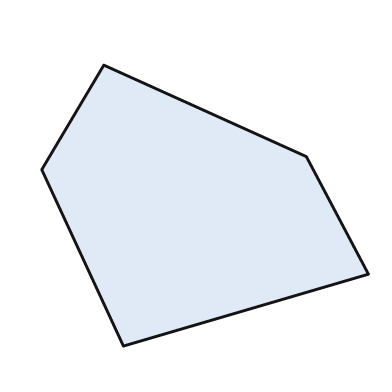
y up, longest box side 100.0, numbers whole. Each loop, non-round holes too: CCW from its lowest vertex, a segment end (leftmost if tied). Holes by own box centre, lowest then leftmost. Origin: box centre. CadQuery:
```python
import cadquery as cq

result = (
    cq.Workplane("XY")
    .moveTo(-25.0, -43.0)
    .lineTo(50.0, -21.0)
    .lineTo(31.0, 15.0)
    .lineTo(-31.0, 43.0)
    .lineTo(-50.0, 11.0)
    .close()
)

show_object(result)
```